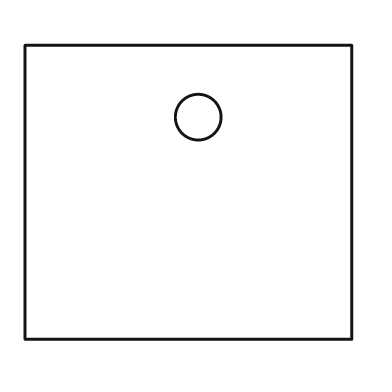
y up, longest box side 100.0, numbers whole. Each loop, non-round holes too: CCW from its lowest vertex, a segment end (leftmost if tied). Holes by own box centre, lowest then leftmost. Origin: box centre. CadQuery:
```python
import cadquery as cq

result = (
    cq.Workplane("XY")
    .moveTo(-50.0, -45.0)
    .lineTo(50.0, -45.0)
    .lineTo(50.0, 45.0)
    .lineTo(-50.0, 45.0)
    .close()
    .moveTo(3.0, 23.0)
    .circle(7.0)
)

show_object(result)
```